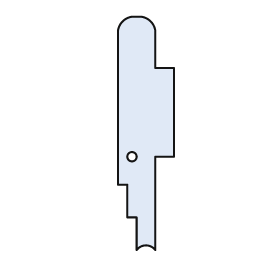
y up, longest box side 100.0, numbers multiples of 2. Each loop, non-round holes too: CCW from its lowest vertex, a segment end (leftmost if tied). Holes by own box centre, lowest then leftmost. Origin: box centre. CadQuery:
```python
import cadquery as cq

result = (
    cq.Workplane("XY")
    .moveTo(-4.0, -50.0)
    .threePointArc((0.0, -48.0), (4.0, -50.0))
    .lineTo(4.0, -10.0)
    .lineTo(12.0, -10.0)
    .lineTo(12.0, 28.0)
    .lineTo(4.0, 28.0)
    .lineTo(4.0, 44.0)
    .threePointArc((2.0, 48.0), (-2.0, 50.0))
    .lineTo(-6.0, 50.0)
    .threePointArc((-10.0, 48.0), (-12.0, 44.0))
    .lineTo(-12.0, -22.0)
    .lineTo(-8.0, -22.0)
    .lineTo(-8.0, -36.0)
    .lineTo(-4.0, -36.0)
    .close()
    .moveTo(-6.0, -10.0)
    .circle(2.0)
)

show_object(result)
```